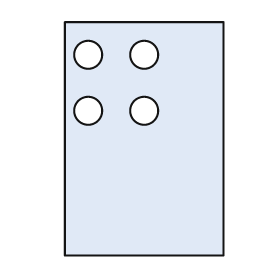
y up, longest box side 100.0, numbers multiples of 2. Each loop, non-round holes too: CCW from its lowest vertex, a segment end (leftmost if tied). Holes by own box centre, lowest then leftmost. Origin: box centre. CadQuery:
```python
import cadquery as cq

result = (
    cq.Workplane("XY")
    .moveTo(-34.0, -50.0)
    .lineTo(34.0, -50.0)
    .lineTo(34.0, 50.0)
    .lineTo(-34.0, 50.0)
    .close()
    .moveTo(-24.0, 12.0)
    .circle(6.0)
    .moveTo(0.0, 12.0)
    .circle(6.0)
    .moveTo(-24.0, 36.0)
    .circle(6.0)
    .moveTo(0.0, 36.0)
    .circle(6.0)
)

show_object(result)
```